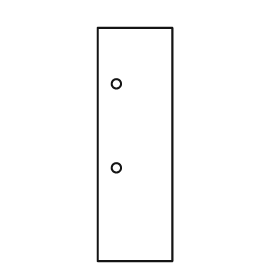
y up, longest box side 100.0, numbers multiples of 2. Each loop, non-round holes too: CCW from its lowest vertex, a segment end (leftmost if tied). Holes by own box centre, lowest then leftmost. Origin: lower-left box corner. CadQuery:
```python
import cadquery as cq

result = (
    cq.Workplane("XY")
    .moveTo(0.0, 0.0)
    .lineTo(32.0, 0.0)
    .lineTo(32.0, 100.0)
    .lineTo(0.0, 100.0)
    .close()
    .moveTo(8.0, 40.0)
    .circle(2.0)
    .moveTo(8.0, 76.0)
    .circle(2.0)
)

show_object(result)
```